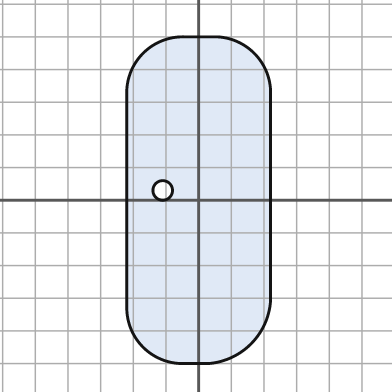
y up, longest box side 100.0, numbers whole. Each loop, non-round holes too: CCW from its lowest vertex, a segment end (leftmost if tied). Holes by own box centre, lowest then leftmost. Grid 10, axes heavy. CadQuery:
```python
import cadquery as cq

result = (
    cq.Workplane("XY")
    .moveTo(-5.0, -50.0)
    .lineTo(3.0, -50.0)
    .threePointArc((16.0, -44.0), (22.0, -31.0))
    .lineTo(22.0, 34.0)
    .threePointArc((17.0, 45.0), (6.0, 50.0))
    .lineTo(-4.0, 50.0)
    .threePointArc((-17.0, 45.0), (-22.0, 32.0))
    .lineTo(-22.0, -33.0)
    .threePointArc((-17.0, -45.0), (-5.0, -50.0))
    .close()
    .moveTo(-11.0, 3.0)
    .circle(3.0)
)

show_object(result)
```